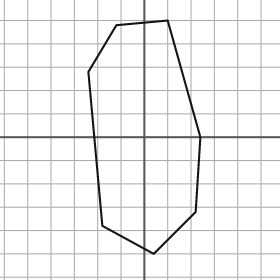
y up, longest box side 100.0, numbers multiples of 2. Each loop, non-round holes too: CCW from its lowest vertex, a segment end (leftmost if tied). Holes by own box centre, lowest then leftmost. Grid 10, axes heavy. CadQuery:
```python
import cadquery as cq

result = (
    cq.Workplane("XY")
    .moveTo(4.0, -50.0)
    .lineTo(22.0, -32.0)
    .lineTo(24.0, 0.0)
    .lineTo(10.0, 50.0)
    .lineTo(-12.0, 48.0)
    .lineTo(-24.0, 28.0)
    .lineTo(-18.0, -38.0)
    .close()
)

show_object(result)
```